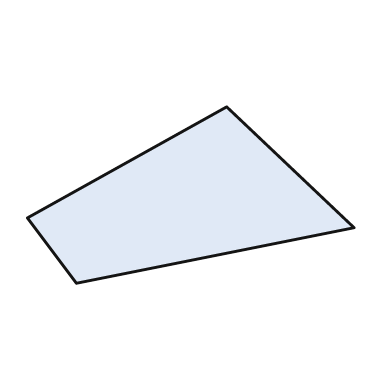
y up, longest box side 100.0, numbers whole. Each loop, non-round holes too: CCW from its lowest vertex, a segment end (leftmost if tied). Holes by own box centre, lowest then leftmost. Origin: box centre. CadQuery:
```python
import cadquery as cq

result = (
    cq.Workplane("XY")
    .moveTo(-35.0, -27.0)
    .lineTo(50.0, -10.0)
    .lineTo(11.0, 27.0)
    .lineTo(-50.0, -7.0)
    .close()
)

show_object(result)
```